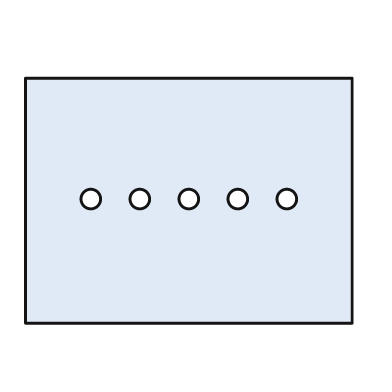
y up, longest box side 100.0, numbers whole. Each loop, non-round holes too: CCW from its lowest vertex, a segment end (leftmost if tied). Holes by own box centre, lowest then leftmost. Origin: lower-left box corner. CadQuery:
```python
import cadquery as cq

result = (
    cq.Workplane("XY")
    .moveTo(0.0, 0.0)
    .lineTo(100.0, 0.0)
    .lineTo(100.0, 75.0)
    .lineTo(0.0, 75.0)
    .close()
    .moveTo(20.0, 38.0)
    .circle(3.0)
    .moveTo(35.0, 38.0)
    .circle(3.0)
    .moveTo(50.0, 38.0)
    .circle(3.0)
    .moveTo(65.0, 38.0)
    .circle(3.0)
    .moveTo(80.0, 38.0)
    .circle(3.0)
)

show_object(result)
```